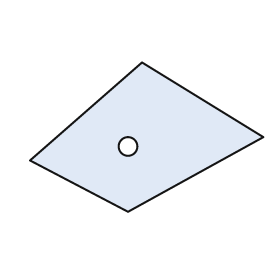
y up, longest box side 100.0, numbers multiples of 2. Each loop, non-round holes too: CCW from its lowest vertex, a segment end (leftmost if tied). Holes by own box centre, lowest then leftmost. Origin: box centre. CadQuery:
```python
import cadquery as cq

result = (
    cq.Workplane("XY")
    .moveTo(-8.0, -32.0)
    .lineTo(50.0, 0.0)
    .lineTo(-2.0, 32.0)
    .lineTo(-50.0, -10.0)
    .close()
    .moveTo(-8.0, -4.0)
    .circle(4.0)
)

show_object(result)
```